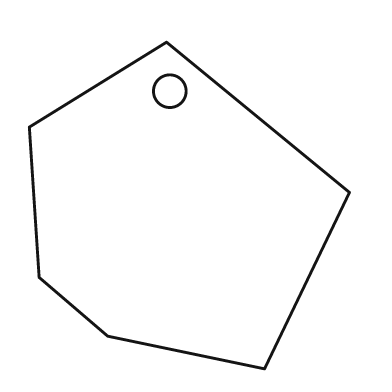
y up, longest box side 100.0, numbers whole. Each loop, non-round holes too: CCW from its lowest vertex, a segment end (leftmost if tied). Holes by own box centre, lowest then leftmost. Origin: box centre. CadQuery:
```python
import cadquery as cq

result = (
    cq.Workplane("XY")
    .moveTo(23.0, -50.0)
    .lineTo(49.0, 4.0)
    .lineTo(-7.0, 50.0)
    .lineTo(-49.0, 24.0)
    .lineTo(-46.0, -22.0)
    .lineTo(-25.0, -40.0)
    .close()
    .moveTo(-6.0, 35.0)
    .circle(5.0)
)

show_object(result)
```